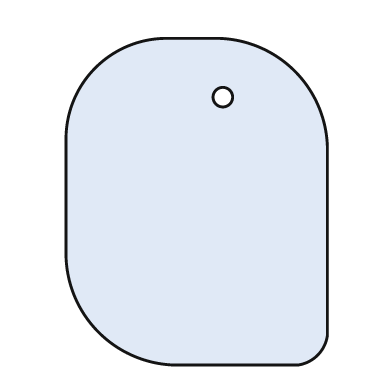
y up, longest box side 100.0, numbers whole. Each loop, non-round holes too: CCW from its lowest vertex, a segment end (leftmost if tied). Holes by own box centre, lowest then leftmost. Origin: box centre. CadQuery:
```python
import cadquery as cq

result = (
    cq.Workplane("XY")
    .moveTo(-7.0, -50.0)
    .lineTo(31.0, -50.0)
    .threePointArc((37.0, -47.0), (40.0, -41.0))
    .lineTo(40.0, 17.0)
    .threePointArc((30.0, 40.0), (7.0, 50.0))
    .lineTo(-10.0, 50.0)
    .threePointArc((-31.0, 41.0), (-40.0, 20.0))
    .lineTo(-40.0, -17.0)
    .threePointArc((-30.0, -40.0), (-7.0, -50.0))
    .close()
    .moveTo(8.0, 32.0)
    .circle(3.0)
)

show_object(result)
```